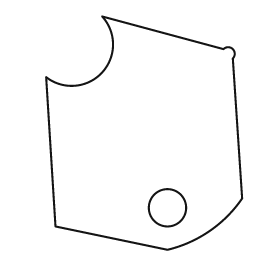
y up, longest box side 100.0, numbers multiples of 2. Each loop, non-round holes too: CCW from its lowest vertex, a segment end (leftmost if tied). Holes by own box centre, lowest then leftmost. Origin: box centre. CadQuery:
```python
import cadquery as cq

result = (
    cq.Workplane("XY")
    .moveTo(10.0, -50.0)
    .threePointArc((28.0, -42.0), (42.0, -28.0))
    .lineTo(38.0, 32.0)
    .threePointArc((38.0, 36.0), (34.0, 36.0))
    .lineTo(-18.0, 50.0)
    .threePointArc((-18.0, 26.0), (-42.0, 24.0))
    .lineTo(-38.0, -40.0)
    .close()
    .moveTo(10.0, -32.0)
    .circle(8.0)
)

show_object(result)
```